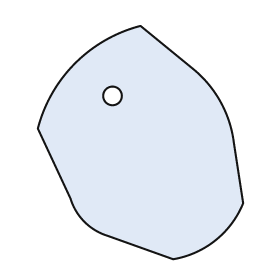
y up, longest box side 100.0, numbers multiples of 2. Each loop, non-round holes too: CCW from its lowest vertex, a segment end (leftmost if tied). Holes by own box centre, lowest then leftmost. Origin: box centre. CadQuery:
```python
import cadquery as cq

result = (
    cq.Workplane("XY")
    .moveTo(14.0, -50.0)
    .threePointArc((32.0, -42.0), (44.0, -26.0))
    .lineTo(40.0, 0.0)
    .threePointArc((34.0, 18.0), (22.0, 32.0))
    .lineTo(0.0, 50.0)
    .threePointArc((-28.0, 34.0), (-44.0, 6.0))
    .lineTo(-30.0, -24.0)
    .threePointArc((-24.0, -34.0), (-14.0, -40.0))
    .close()
    .moveTo(-12.0, 20.0)
    .circle(4.0)
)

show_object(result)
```